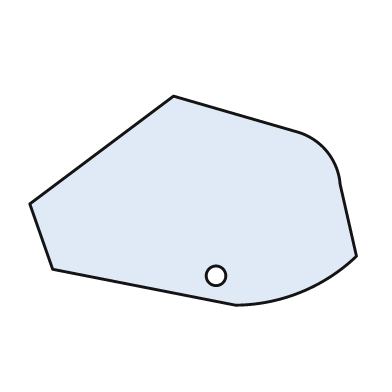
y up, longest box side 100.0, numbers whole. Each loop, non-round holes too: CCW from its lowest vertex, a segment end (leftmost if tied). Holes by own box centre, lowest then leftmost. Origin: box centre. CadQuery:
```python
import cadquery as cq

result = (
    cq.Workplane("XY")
    .moveTo(13.0, -32.0)
    .threePointArc((33.0, -28.0), (50.0, -17.0))
    .lineTo(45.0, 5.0)
    .threePointArc((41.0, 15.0), (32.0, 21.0))
    .lineTo(-6.0, 32.0)
    .lineTo(-50.0, -1.0)
    .lineTo(-43.0, -21.0)
    .close()
    .moveTo(7.0, -23.0)
    .circle(3.0)
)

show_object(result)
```